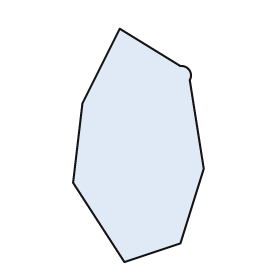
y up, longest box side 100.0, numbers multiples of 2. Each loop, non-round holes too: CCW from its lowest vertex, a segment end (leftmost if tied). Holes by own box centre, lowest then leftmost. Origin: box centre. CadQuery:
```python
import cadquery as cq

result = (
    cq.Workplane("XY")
    .moveTo(-6.0, -50.0)
    .lineTo(18.0, -42.0)
    .lineTo(28.0, -10.0)
    .lineTo(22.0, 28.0)
    .threePointArc((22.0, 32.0), (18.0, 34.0))
    .lineTo(-8.0, 50.0)
    .lineTo(-24.0, 18.0)
    .lineTo(-28.0, -16.0)
    .close()
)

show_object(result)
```